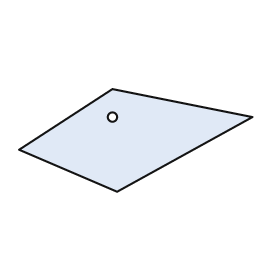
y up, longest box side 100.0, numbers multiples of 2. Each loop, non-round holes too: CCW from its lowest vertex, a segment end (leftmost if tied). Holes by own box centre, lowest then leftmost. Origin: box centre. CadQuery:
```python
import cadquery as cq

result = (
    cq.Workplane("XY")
    .moveTo(-8.0, -22.0)
    .lineTo(50.0, 10.0)
    .lineTo(-10.0, 22.0)
    .lineTo(-50.0, -4.0)
    .close()
    .moveTo(-10.0, 10.0)
    .circle(2.0)
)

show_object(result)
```